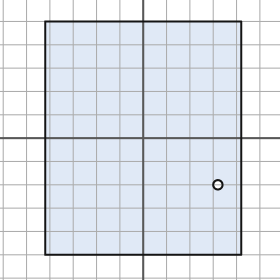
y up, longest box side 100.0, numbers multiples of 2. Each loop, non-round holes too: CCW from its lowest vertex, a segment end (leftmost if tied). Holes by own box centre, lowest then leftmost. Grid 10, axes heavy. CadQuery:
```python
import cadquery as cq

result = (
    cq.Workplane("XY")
    .moveTo(-42.0, -50.0)
    .lineTo(42.0, -50.0)
    .lineTo(42.0, 50.0)
    .lineTo(-42.0, 50.0)
    .close()
    .moveTo(32.0, -20.0)
    .circle(2.0)
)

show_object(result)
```